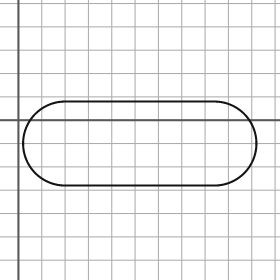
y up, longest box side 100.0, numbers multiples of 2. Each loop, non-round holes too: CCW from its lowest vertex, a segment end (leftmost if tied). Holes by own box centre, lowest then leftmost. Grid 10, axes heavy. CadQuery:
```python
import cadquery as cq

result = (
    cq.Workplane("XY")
    .moveTo(20.0, -28.0)
    .lineTo(84.0, -28.0)
    .threePointArc((102.0, -10.0), (84.0, 8.0))
    .lineTo(20.0, 8.0)
    .threePointArc((2.0, -10.0), (20.0, -28.0))
    .close()
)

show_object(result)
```